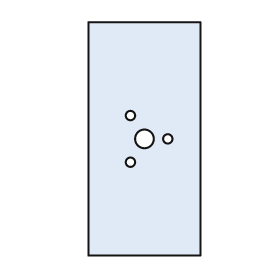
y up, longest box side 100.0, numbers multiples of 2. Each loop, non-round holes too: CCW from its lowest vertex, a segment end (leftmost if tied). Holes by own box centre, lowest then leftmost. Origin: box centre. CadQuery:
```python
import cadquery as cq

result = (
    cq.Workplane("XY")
    .moveTo(-24.0, -50.0)
    .lineTo(24.0, -50.0)
    .lineTo(24.0, 50.0)
    .lineTo(-24.0, 50.0)
    .close()
    .moveTo(-6.0, -10.0)
    .circle(2.0)
    .moveTo(0.0, 0.0)
    .circle(4.0)
    .moveTo(10.0, 0.0)
    .circle(2.0)
    .moveTo(-6.0, 10.0)
    .circle(2.0)
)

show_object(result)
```